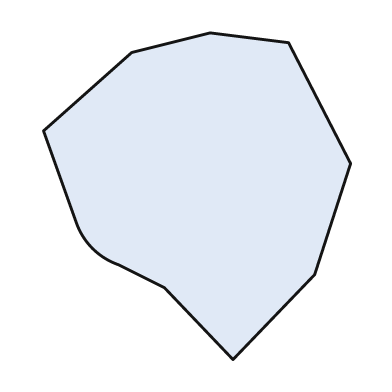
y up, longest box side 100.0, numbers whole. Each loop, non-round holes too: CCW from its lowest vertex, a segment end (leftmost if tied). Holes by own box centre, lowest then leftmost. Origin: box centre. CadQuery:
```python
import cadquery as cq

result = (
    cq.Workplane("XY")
    .moveTo(11.0, -50.0)
    .lineTo(36.0, -24.0)
    .lineTo(47.0, 10.0)
    .lineTo(28.0, 47.0)
    .lineTo(4.0, 50.0)
    .lineTo(-20.0, 44.0)
    .lineTo(-47.0, 20.0)
    .lineTo(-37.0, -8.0)
    .threePointArc((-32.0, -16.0), (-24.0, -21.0))
    .lineTo(-10.0, -28.0)
    .close()
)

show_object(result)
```